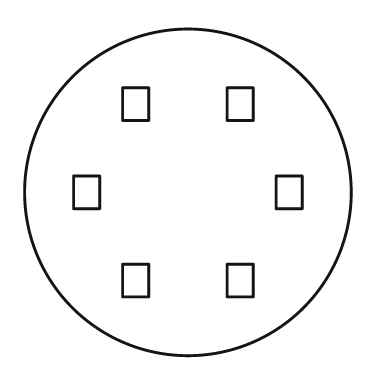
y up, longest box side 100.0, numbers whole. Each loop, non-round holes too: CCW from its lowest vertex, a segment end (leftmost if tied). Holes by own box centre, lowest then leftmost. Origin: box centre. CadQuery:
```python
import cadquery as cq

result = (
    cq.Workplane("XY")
    .moveTo(0.0, 0.0)
    .circle(50.0)
    .moveTo(-20.0, -32.0)
    .lineTo(-12.0, -32.0)
    .lineTo(-12.0, -22.0)
    .lineTo(-20.0, -22.0)
    .close()
    .moveTo(12.0, -32.0)
    .lineTo(20.0, -32.0)
    .lineTo(20.0, -22.0)
    .lineTo(12.0, -22.0)
    .close()
    .moveTo(-35.0, -5.0)
    .lineTo(-27.0, -5.0)
    .lineTo(-27.0, 5.0)
    .lineTo(-35.0, 5.0)
    .close()
    .moveTo(27.0, -5.0)
    .lineTo(35.0, -5.0)
    .lineTo(35.0, 5.0)
    .lineTo(27.0, 5.0)
    .close()
    .moveTo(-20.0, 22.0)
    .lineTo(-12.0, 22.0)
    .lineTo(-12.0, 32.0)
    .lineTo(-20.0, 32.0)
    .close()
    .moveTo(12.0, 22.0)
    .lineTo(20.0, 22.0)
    .lineTo(20.0, 32.0)
    .lineTo(12.0, 32.0)
    .close()
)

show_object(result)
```